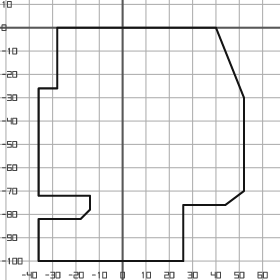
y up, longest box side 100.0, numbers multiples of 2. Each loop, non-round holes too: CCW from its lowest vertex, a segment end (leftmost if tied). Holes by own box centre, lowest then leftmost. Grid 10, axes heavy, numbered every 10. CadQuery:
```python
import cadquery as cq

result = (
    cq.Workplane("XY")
    .moveTo(-36.0, -100.0)
    .lineTo(26.0, -100.0)
    .lineTo(26.0, -76.0)
    .lineTo(44.0, -76.0)
    .lineTo(52.0, -70.0)
    .lineTo(52.0, -30.0)
    .lineTo(40.0, 0.0)
    .lineTo(-28.0, 0.0)
    .lineTo(-28.0, -26.0)
    .lineTo(-36.0, -26.0)
    .lineTo(-36.0, -72.0)
    .lineTo(-14.0, -72.0)
    .lineTo(-14.0, -78.0)
    .lineTo(-18.0, -82.0)
    .lineTo(-36.0, -82.0)
    .close()
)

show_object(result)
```